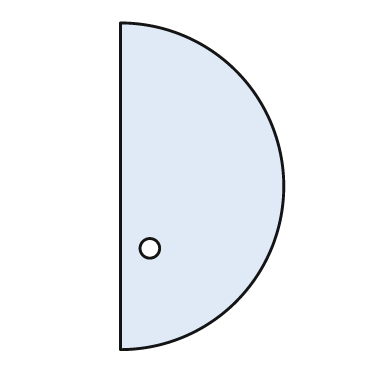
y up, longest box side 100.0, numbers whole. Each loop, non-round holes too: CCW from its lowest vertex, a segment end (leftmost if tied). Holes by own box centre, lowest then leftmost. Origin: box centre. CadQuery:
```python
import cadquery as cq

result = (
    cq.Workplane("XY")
    .moveTo(-25.0, -50.0)
    .threePointArc((25.0, 0.0), (-25.0, 50.0))
    .close()
    .moveTo(-16.0, -19.0)
    .circle(3.0)
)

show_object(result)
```